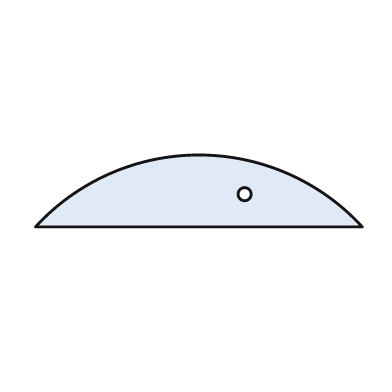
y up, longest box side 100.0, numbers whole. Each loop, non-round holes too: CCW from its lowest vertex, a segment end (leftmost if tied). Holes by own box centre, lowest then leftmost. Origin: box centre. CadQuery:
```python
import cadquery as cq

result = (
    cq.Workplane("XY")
    .moveTo(-50.0, -11.0)
    .lineTo(50.0, -11.0)
    .threePointArc((0.0, 11.0), (-50.0, -11.0))
    .close()
    .moveTo(14.0, -1.0)
    .circle(2.0)
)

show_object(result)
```